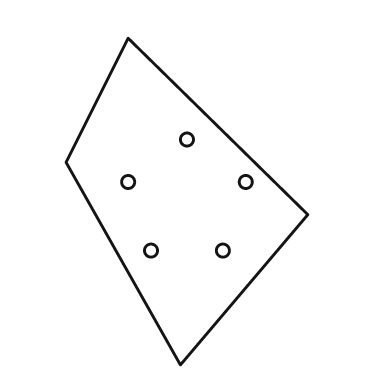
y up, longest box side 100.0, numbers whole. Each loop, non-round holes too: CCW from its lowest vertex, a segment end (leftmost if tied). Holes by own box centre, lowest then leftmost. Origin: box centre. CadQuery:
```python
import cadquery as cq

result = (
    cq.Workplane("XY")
    .moveTo(-2.0, -50.0)
    .lineTo(37.0, -4.0)
    .lineTo(-18.0, 50.0)
    .lineTo(-37.0, 12.0)
    .close()
    .moveTo(-11.0, -15.0)
    .circle(2.0)
    .moveTo(11.0, -15.0)
    .circle(2.0)
    .moveTo(-18.0, 6.0)
    .circle(2.0)
    .moveTo(18.0, 6.0)
    .circle(2.0)
    .moveTo(0.0, 19.0)
    .circle(2.0)
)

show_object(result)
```